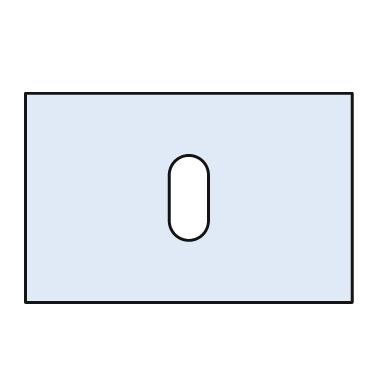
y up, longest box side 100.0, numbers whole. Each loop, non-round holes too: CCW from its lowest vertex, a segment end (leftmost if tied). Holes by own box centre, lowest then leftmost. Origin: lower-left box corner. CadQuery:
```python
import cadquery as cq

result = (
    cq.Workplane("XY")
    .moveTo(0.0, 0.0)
    .lineTo(100.0, 0.0)
    .lineTo(100.0, 64.0)
    .lineTo(0.0, 64.0)
    .close()
    .moveTo(44.0, 25.0)
    .threePointArc((50.0, 19.0), (56.0, 25.0))
    .lineTo(56.0, 39.0)
    .threePointArc((50.0, 45.0), (44.0, 39.0))
    .close()
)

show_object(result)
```